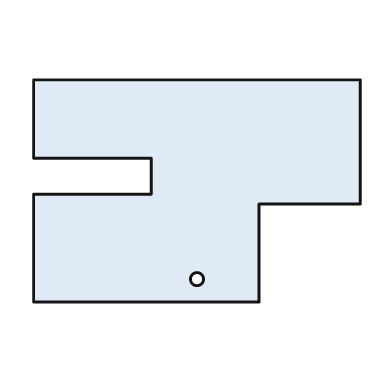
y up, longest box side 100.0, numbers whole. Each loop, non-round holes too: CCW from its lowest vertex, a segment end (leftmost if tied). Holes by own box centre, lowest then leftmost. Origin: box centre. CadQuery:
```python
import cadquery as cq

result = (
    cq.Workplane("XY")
    .moveTo(-50.0, -34.0)
    .lineTo(19.0, -34.0)
    .lineTo(19.0, -4.0)
    .lineTo(50.0, -4.0)
    .lineTo(50.0, 34.0)
    .lineTo(-50.0, 34.0)
    .lineTo(-50.0, 10.0)
    .lineTo(-14.0, 10.0)
    .lineTo(-14.0, -1.0)
    .lineTo(-50.0, -1.0)
    .close()
    .moveTo(0.0, -27.0)
    .circle(2.0)
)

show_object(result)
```